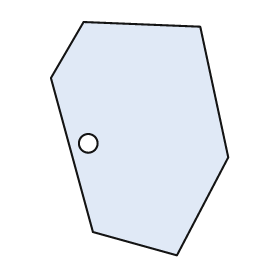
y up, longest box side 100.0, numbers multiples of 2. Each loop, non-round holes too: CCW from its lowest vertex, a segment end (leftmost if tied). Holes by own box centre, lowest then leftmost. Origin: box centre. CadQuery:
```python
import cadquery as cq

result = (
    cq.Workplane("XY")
    .moveTo(16.0, -50.0)
    .lineTo(38.0, -8.0)
    .lineTo(26.0, 48.0)
    .lineTo(-24.0, 50.0)
    .lineTo(-38.0, 26.0)
    .lineTo(-20.0, -40.0)
    .close()
    .moveTo(-22.0, -2.0)
    .circle(4.0)
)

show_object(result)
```